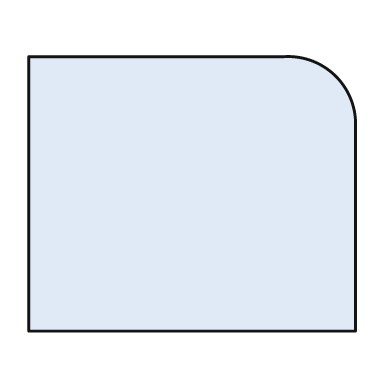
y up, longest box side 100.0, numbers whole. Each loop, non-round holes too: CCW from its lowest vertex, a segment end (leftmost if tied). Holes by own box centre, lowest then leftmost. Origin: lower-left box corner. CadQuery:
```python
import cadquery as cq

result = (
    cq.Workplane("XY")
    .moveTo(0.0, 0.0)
    .lineTo(100.0, 0.0)
    .lineTo(100.0, 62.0)
    .threePointArc((94.0, 78.0), (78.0, 84.0))
    .lineTo(0.0, 84.0)
    .close()
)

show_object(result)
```